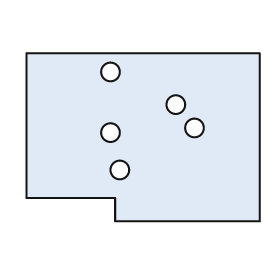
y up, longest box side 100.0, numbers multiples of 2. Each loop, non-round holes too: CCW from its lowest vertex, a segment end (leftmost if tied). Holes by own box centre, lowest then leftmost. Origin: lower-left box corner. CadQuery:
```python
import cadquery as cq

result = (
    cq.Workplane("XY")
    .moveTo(38.0, 0.0)
    .lineTo(100.0, 0.0)
    .lineTo(100.0, 72.0)
    .lineTo(0.0, 72.0)
    .lineTo(0.0, 10.0)
    .lineTo(38.0, 10.0)
    .close()
    .moveTo(40.0, 22.0)
    .circle(4.0)
    .moveTo(36.0, 38.0)
    .circle(4.0)
    .moveTo(72.0, 40.0)
    .circle(4.0)
    .moveTo(64.0, 50.0)
    .circle(4.0)
    .moveTo(36.0, 64.0)
    .circle(4.0)
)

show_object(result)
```